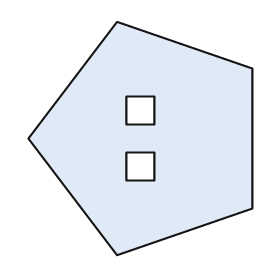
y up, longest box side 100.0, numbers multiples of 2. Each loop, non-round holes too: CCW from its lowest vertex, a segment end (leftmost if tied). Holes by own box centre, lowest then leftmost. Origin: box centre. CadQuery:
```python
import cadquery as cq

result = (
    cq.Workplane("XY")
    .moveTo(-10.0, -50.0)
    .lineTo(48.0, -30.0)
    .lineTo(48.0, 30.0)
    .lineTo(-10.0, 50.0)
    .lineTo(-48.0, 0.0)
    .close()
    .moveTo(-6.0, -18.0)
    .lineTo(6.0, -18.0)
    .lineTo(6.0, -6.0)
    .lineTo(-6.0, -6.0)
    .close()
    .moveTo(-6.0, 6.0)
    .lineTo(6.0, 6.0)
    .lineTo(6.0, 18.0)
    .lineTo(-6.0, 18.0)
    .close()
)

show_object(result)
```